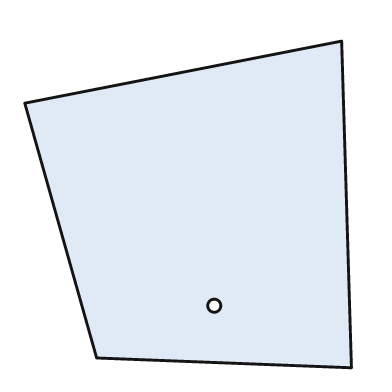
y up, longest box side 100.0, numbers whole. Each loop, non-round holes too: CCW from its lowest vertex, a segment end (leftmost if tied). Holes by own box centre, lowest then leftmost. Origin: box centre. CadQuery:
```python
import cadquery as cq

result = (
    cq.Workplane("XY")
    .moveTo(50.0, -50.0)
    .lineTo(47.0, 50.0)
    .lineTo(-50.0, 31.0)
    .lineTo(-28.0, -47.0)
    .close()
    .moveTo(8.0, -31.0)
    .circle(2.0)
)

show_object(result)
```